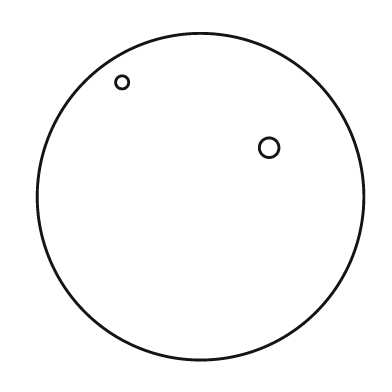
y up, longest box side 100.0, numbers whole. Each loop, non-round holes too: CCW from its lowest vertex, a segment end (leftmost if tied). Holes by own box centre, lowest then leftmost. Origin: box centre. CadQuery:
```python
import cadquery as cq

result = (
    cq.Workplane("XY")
    .moveTo(0.0, 0.0)
    .circle(50.0)
    .moveTo(21.0, 15.0)
    .circle(3.0)
    .moveTo(-24.0, 35.0)
    .circle(2.0)
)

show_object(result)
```